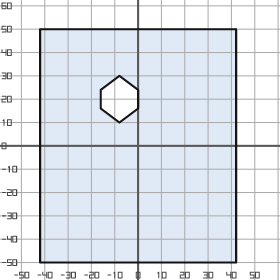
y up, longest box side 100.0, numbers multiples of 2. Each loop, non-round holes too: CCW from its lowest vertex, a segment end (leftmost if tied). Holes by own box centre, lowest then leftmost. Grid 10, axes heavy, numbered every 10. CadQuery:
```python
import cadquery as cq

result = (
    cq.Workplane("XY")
    .moveTo(-42.0, -50.0)
    .lineTo(42.0, -50.0)
    .lineTo(42.0, 50.0)
    .lineTo(-42.0, 50.0)
    .close()
    .moveTo(-8.0, 10.0)
    .lineTo(0.0, 16.0)
    .lineTo(0.0, 24.0)
    .lineTo(-8.0, 30.0)
    .lineTo(-16.0, 24.0)
    .lineTo(-16.0, 16.0)
    .close()
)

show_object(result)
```